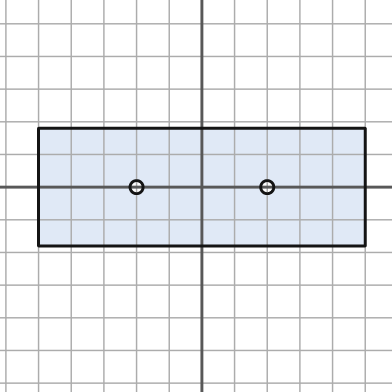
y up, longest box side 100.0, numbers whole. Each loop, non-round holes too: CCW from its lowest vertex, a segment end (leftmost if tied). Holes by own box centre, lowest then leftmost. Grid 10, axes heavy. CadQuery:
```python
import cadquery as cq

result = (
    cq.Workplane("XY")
    .moveTo(-50.0, -18.0)
    .lineTo(50.0, -18.0)
    .lineTo(50.0, 18.0)
    .lineTo(-50.0, 18.0)
    .close()
    .moveTo(-20.0, 0.0)
    .circle(2.0)
    .moveTo(20.0, 0.0)
    .circle(2.0)
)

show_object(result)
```